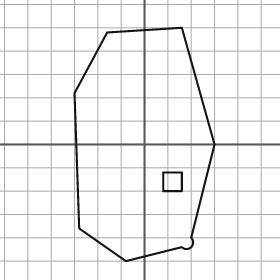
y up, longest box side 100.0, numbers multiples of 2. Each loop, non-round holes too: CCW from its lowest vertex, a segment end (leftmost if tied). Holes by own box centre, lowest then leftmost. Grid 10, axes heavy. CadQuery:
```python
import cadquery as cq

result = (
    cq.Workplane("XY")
    .moveTo(-8.0, -50.0)
    .lineTo(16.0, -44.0)
    .threePointArc((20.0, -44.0), (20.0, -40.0))
    .lineTo(30.0, 0.0)
    .lineTo(16.0, 50.0)
    .lineTo(-16.0, 48.0)
    .lineTo(-30.0, 22.0)
    .lineTo(-28.0, -36.0)
    .close()
    .moveTo(8.0, -20.0)
    .lineTo(16.0, -20.0)
    .lineTo(16.0, -12.0)
    .lineTo(8.0, -12.0)
    .close()
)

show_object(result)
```